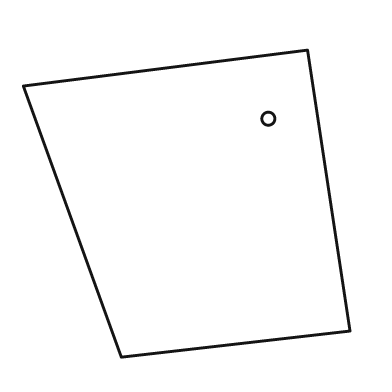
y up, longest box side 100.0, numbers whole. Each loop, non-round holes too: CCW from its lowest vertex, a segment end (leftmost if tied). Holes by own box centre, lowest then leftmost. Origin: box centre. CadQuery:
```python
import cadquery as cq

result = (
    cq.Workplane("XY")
    .moveTo(-20.0, -47.0)
    .lineTo(50.0, -39.0)
    .lineTo(37.0, 47.0)
    .lineTo(-50.0, 36.0)
    .close()
    .moveTo(25.0, 26.0)
    .circle(2.0)
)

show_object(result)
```